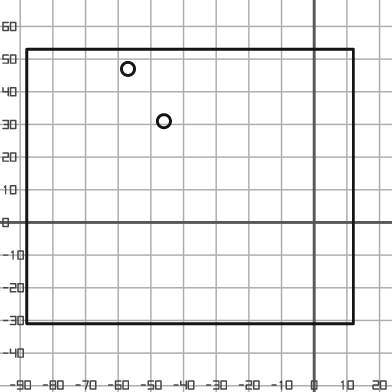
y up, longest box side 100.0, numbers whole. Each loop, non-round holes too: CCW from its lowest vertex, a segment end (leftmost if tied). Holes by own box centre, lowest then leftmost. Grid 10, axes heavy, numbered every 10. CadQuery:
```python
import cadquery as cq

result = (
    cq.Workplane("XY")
    .moveTo(-88.0, -31.0)
    .lineTo(12.0, -31.0)
    .lineTo(12.0, 53.0)
    .lineTo(-88.0, 53.0)
    .close()
    .moveTo(-46.0, 31.0)
    .circle(2.0)
    .moveTo(-57.0, 47.0)
    .circle(2.0)
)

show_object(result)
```